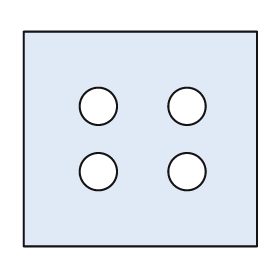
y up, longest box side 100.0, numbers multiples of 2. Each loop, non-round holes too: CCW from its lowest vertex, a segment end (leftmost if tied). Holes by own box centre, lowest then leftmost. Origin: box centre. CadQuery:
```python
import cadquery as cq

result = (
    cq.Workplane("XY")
    .moveTo(-50.0, -46.0)
    .lineTo(50.0, -46.0)
    .lineTo(50.0, 46.0)
    .lineTo(-50.0, 46.0)
    .close()
    .moveTo(-18.0, -14.0)
    .circle(8.0)
    .moveTo(20.0, -14.0)
    .circle(8.0)
    .moveTo(-18.0, 14.0)
    .circle(8.0)
    .moveTo(20.0, 14.0)
    .circle(8.0)
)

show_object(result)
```